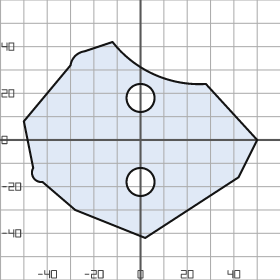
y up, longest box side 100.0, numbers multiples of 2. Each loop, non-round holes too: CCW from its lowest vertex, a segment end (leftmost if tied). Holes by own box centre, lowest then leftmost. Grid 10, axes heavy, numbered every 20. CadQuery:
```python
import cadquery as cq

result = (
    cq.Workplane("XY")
    .moveTo(2.0, -42.0)
    .lineTo(42.0, -16.0)
    .lineTo(50.0, 0.0)
    .lineTo(28.0, 24.0)
    .threePointArc((6.0, 28.0), (-12.0, 42.0))
    .lineTo(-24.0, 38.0)
    .threePointArc((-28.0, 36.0), (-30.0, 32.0))
    .lineTo(-50.0, 8.0)
    .lineTo(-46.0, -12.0)
    .threePointArc((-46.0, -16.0), (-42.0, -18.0))
    .lineTo(-28.0, -30.0)
    .close()
    .moveTo(0.0, -18.0)
    .circle(6.0)
    .moveTo(0.0, 18.0)
    .circle(6.0)
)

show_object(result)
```